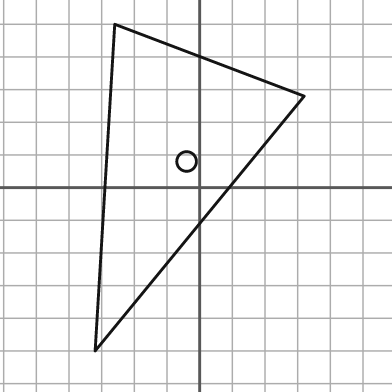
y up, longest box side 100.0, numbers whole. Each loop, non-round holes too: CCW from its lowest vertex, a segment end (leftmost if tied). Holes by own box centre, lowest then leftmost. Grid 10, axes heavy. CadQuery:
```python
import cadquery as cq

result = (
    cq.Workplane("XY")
    .moveTo(-32.0, -50.0)
    .lineTo(32.0, 28.0)
    .lineTo(-26.0, 50.0)
    .close()
    .moveTo(-4.0, 8.0)
    .circle(3.0)
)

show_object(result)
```